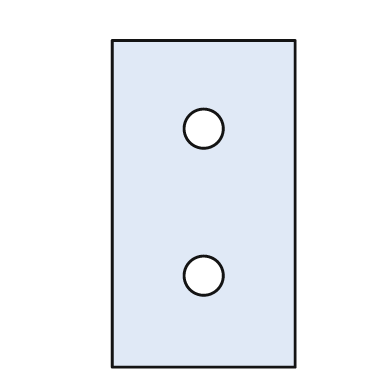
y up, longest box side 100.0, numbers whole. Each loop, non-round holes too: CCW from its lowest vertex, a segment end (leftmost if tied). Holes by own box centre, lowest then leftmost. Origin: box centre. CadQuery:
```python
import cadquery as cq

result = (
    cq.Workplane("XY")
    .moveTo(-28.0, -50.0)
    .lineTo(28.0, -50.0)
    .lineTo(28.0, 50.0)
    .lineTo(-28.0, 50.0)
    .close()
    .moveTo(0.0, -22.0)
    .circle(6.0)
    .moveTo(0.0, 23.0)
    .circle(6.0)
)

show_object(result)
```